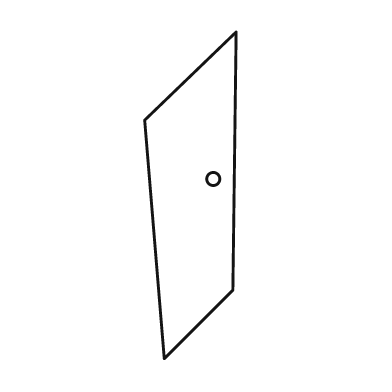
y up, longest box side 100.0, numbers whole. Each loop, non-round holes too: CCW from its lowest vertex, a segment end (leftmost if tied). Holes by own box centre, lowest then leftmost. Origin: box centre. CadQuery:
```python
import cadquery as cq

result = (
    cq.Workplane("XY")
    .moveTo(-8.0, -50.0)
    .lineTo(13.0, -29.0)
    .lineTo(14.0, 50.0)
    .lineTo(-14.0, 23.0)
    .close()
    .moveTo(7.0, 5.0)
    .circle(2.0)
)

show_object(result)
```